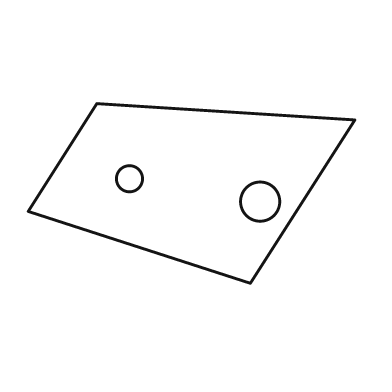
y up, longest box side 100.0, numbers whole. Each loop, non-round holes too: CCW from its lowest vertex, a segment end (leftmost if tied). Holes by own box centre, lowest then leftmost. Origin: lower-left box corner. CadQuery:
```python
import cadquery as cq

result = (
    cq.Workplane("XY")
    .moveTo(68.0, 0.0)
    .lineTo(100.0, 50.0)
    .lineTo(21.0, 55.0)
    .lineTo(0.0, 22.0)
    .close()
    .moveTo(71.0, 25.0)
    .circle(6.0)
    .moveTo(31.0, 32.0)
    .circle(4.0)
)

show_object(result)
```